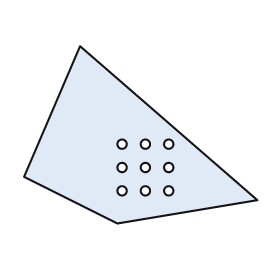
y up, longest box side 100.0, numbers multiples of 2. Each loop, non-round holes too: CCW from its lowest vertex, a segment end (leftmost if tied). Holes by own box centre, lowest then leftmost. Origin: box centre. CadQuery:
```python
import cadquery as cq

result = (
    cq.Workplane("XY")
    .moveTo(-10.0, -38.0)
    .lineTo(50.0, -28.0)
    .lineTo(-26.0, 38.0)
    .lineTo(-50.0, -18.0)
    .close()
    .moveTo(-8.0, -24.0)
    .circle(2.0)
    .moveTo(2.0, -24.0)
    .circle(2.0)
    .moveTo(12.0, -24.0)
    .circle(2.0)
    .moveTo(-8.0, -14.0)
    .circle(2.0)
    .moveTo(2.0, -14.0)
    .circle(2.0)
    .moveTo(12.0, -14.0)
    .circle(2.0)
    .moveTo(-8.0, -4.0)
    .circle(2.0)
    .moveTo(2.0, -4.0)
    .circle(2.0)
    .moveTo(12.0, -4.0)
    .circle(2.0)
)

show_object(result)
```